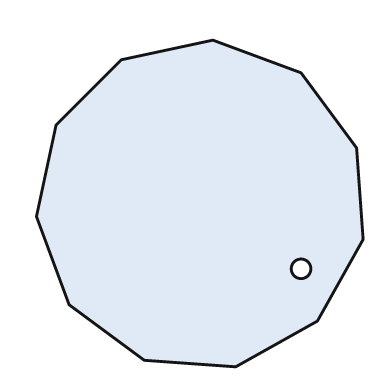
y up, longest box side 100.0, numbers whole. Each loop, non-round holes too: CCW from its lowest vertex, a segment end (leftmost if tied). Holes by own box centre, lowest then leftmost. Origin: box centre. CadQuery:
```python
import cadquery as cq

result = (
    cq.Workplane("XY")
    .moveTo(11.0, -50.0)
    .lineTo(36.0, -36.0)
    .lineTo(50.0, -11.0)
    .lineTo(48.0, 17.0)
    .lineTo(31.0, 40.0)
    .lineTo(4.0, 50.0)
    .lineTo(-24.0, 44.0)
    .lineTo(-44.0, 24.0)
    .lineTo(-50.0, -4.0)
    .lineTo(-40.0, -31.0)
    .lineTo(-17.0, -48.0)
    .close()
    .moveTo(31.0, -20.0)
    .circle(3.0)
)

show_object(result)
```